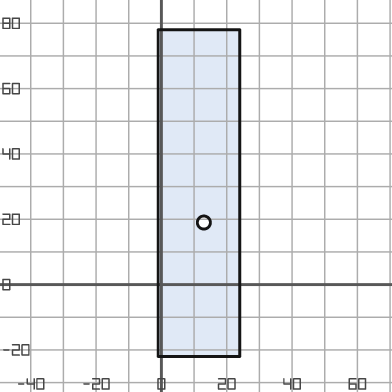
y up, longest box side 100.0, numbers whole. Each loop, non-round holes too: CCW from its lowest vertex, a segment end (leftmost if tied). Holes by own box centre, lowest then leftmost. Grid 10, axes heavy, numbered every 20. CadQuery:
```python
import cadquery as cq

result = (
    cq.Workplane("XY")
    .moveTo(-1.0, -22.0)
    .lineTo(24.0, -22.0)
    .lineTo(24.0, 78.0)
    .lineTo(-1.0, 78.0)
    .close()
    .moveTo(13.0, 19.0)
    .circle(2.0)
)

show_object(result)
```